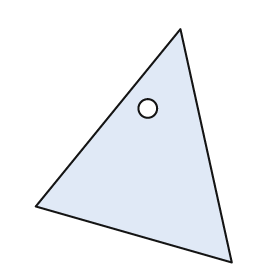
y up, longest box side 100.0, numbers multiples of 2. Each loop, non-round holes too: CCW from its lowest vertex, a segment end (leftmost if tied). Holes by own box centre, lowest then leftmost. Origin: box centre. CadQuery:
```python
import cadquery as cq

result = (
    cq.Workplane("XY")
    .moveTo(42.0, -50.0)
    .lineTo(20.0, 50.0)
    .lineTo(-42.0, -26.0)
    .close()
    .moveTo(6.0, 16.0)
    .circle(4.0)
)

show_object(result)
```